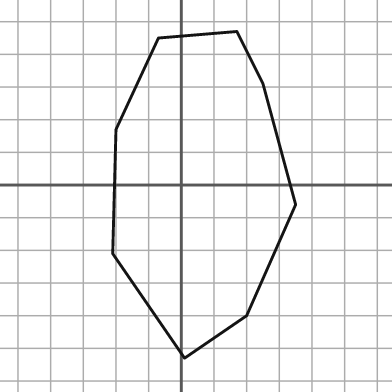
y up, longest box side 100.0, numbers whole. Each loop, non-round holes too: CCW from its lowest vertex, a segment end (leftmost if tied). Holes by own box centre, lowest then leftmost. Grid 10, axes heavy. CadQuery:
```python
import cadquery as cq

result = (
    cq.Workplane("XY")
    .moveTo(1.0, -53.0)
    .lineTo(20.0, -40.0)
    .lineTo(35.0, -6.0)
    .lineTo(25.0, 31.0)
    .lineTo(17.0, 47.0)
    .lineTo(-7.0, 45.0)
    .lineTo(-20.0, 17.0)
    .lineTo(-21.0, -21.0)
    .close()
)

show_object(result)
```